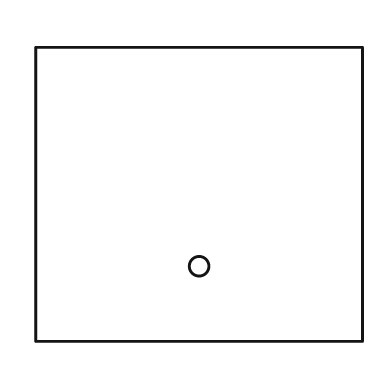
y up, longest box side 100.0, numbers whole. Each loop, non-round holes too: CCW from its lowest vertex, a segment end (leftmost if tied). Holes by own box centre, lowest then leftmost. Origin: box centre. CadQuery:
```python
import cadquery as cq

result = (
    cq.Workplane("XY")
    .moveTo(-50.0, -45.0)
    .lineTo(50.0, -45.0)
    .lineTo(50.0, 45.0)
    .lineTo(-50.0, 45.0)
    .close()
    .moveTo(0.0, -22.0)
    .circle(3.0)
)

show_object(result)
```